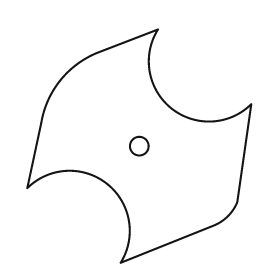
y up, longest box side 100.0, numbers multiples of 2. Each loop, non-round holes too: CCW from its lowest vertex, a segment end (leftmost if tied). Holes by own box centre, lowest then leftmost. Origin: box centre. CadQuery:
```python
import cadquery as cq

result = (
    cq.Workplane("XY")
    .moveTo(-8.0, -50.0)
    .lineTo(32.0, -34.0)
    .threePointArc((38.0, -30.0), (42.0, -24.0))
    .lineTo(48.0, 18.0)
    .threePointArc((14.0, 16.0), (8.0, 50.0))
    .lineTo(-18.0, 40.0)
    .threePointArc((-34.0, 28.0), (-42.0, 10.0))
    .lineTo(-48.0, -18.0)
    .threePointArc((-14.0, -16.0), (-8.0, -50.0))
    .close()
    .moveTo(0.0, 0.0)
    .circle(4.0)
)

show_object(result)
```